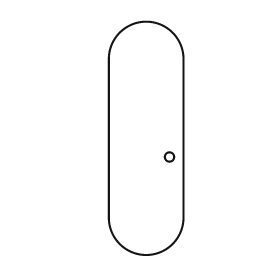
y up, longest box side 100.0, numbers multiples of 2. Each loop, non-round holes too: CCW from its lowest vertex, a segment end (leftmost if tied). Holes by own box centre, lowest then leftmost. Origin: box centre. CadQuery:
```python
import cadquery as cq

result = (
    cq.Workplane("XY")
    .moveTo(-16.0, -34.0)
    .threePointArc((0.0, -50.0), (16.0, -34.0))
    .lineTo(16.0, 34.0)
    .threePointArc((0.0, 50.0), (-16.0, 34.0))
    .close()
    .moveTo(10.0, -8.0)
    .circle(2.0)
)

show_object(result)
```